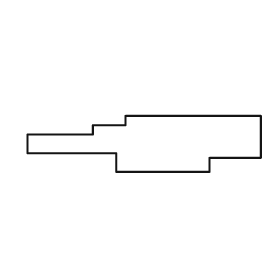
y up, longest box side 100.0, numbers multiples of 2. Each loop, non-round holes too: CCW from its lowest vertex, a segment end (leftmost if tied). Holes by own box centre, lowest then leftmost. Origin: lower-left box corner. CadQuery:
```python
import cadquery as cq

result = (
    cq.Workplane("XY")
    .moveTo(38.0, 0.0)
    .lineTo(78.0, 0.0)
    .lineTo(78.0, 6.0)
    .lineTo(100.0, 6.0)
    .lineTo(100.0, 24.0)
    .lineTo(42.0, 24.0)
    .lineTo(42.0, 20.0)
    .lineTo(28.0, 20.0)
    .lineTo(28.0, 16.0)
    .lineTo(0.0, 16.0)
    .lineTo(0.0, 8.0)
    .lineTo(38.0, 8.0)
    .close()
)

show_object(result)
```